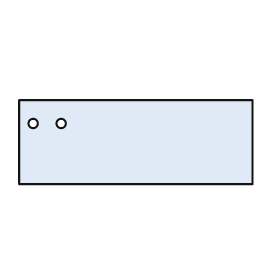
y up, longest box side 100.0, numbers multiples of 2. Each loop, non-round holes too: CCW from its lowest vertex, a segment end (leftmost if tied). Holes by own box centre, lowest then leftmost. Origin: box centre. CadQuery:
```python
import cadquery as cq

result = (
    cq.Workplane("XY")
    .moveTo(-50.0, -18.0)
    .lineTo(50.0, -18.0)
    .lineTo(50.0, 18.0)
    .lineTo(-50.0, 18.0)
    .close()
    .moveTo(-44.0, 8.0)
    .circle(2.0)
    .moveTo(-32.0, 8.0)
    .circle(2.0)
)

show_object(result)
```